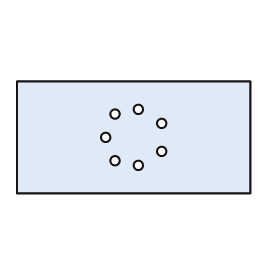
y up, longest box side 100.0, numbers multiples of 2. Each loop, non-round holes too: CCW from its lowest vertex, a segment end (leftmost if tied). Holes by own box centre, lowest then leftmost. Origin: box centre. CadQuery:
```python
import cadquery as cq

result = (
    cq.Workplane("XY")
    .moveTo(-50.0, -24.0)
    .lineTo(50.0, -24.0)
    .lineTo(50.0, 24.0)
    .lineTo(-50.0, 24.0)
    .close()
    .moveTo(2.0, -12.0)
    .circle(2.0)
    .moveTo(-8.0, -10.0)
    .circle(2.0)
    .moveTo(12.0, -6.0)
    .circle(2.0)
    .moveTo(-12.0, 0.0)
    .circle(2.0)
    .moveTo(12.0, 6.0)
    .circle(2.0)
    .moveTo(-8.0, 10.0)
    .circle(2.0)
    .moveTo(2.0, 12.0)
    .circle(2.0)
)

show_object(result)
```